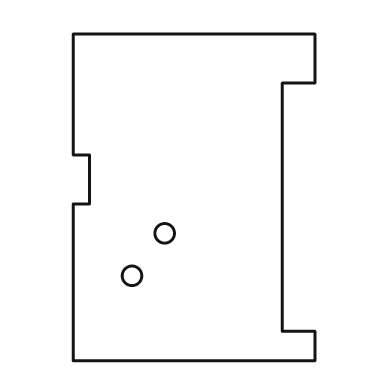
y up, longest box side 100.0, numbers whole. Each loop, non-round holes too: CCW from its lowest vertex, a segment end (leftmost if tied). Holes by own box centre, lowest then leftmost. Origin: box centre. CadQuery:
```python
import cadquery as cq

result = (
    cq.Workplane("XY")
    .moveTo(-37.0, -50.0)
    .lineTo(37.0, -50.0)
    .lineTo(37.0, -41.0)
    .lineTo(27.0, -41.0)
    .lineTo(27.0, 35.0)
    .lineTo(37.0, 35.0)
    .lineTo(37.0, 50.0)
    .lineTo(-37.0, 50.0)
    .lineTo(-37.0, 13.0)
    .lineTo(-32.0, 13.0)
    .lineTo(-32.0, -2.0)
    .lineTo(-37.0, -2.0)
    .close()
    .moveTo(-19.0, -24.0)
    .circle(3.0)
    .moveTo(-9.0, -11.0)
    .circle(3.0)
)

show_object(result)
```